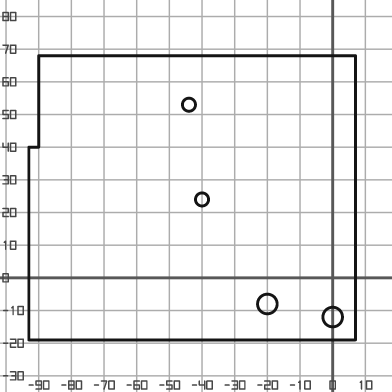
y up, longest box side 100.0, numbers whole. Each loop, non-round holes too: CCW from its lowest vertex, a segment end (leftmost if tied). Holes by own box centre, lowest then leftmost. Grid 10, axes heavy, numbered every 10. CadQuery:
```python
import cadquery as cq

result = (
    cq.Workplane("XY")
    .moveTo(-93.0, -19.0)
    .lineTo(7.0, -19.0)
    .lineTo(7.0, 68.0)
    .lineTo(-90.0, 68.0)
    .lineTo(-90.0, 40.0)
    .lineTo(-93.0, 40.0)
    .close()
    .moveTo(0.0, -12.0)
    .circle(3.0)
    .moveTo(-20.0, -8.0)
    .circle(3.0)
    .moveTo(-40.0, 24.0)
    .circle(2.0)
    .moveTo(-44.0, 53.0)
    .circle(2.0)
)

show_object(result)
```